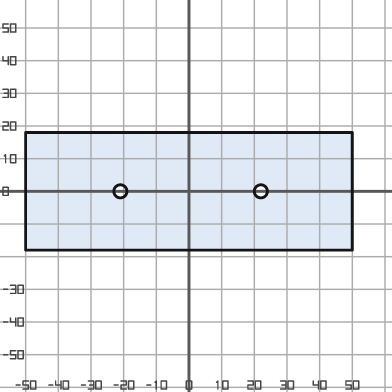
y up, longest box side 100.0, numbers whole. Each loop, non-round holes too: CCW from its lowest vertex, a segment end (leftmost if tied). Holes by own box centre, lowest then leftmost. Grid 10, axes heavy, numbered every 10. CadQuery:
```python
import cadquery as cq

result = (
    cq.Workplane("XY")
    .moveTo(-50.0, -18.0)
    .lineTo(50.0, -18.0)
    .lineTo(50.0, 18.0)
    .lineTo(-50.0, 18.0)
    .close()
    .moveTo(-21.0, 0.0)
    .circle(2.0)
    .moveTo(22.0, 0.0)
    .circle(2.0)
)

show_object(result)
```